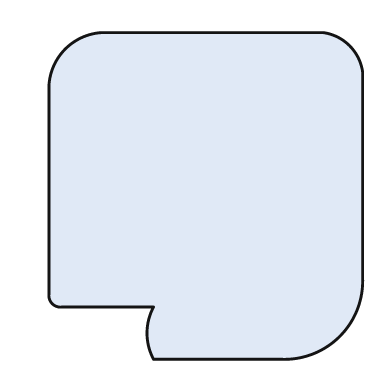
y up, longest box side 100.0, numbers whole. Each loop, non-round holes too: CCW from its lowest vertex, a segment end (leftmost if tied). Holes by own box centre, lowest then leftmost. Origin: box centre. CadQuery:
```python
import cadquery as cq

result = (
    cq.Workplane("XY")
    .moveTo(-16.0, -50.0)
    .lineTo(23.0, -50.0)
    .threePointArc((41.0, -43.0), (48.0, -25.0))
    .lineTo(48.0, 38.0)
    .threePointArc((44.0, 46.0), (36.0, 50.0))
    .lineTo(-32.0, 50.0)
    .threePointArc((-43.0, 45.0), (-48.0, 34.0))
    .lineTo(-48.0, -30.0)
    .threePointArc((-47.0, -33.0), (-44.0, -34.0))
    .lineTo(-16.0, -34.0)
    .threePointArc((-18.0, -42.0), (-16.0, -50.0))
    .close()
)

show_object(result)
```